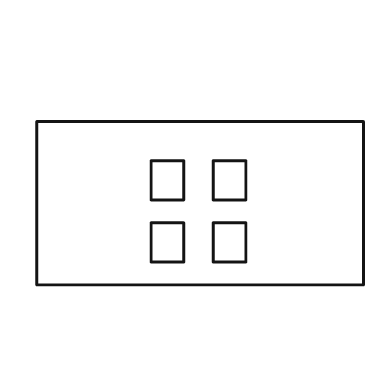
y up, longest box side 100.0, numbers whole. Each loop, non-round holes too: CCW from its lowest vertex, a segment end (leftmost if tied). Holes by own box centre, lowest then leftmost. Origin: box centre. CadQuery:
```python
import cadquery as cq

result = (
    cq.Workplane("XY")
    .moveTo(-50.0, -25.0)
    .lineTo(50.0, -25.0)
    .lineTo(50.0, 25.0)
    .lineTo(-50.0, 25.0)
    .close()
    .moveTo(-15.0, -18.0)
    .lineTo(-5.0, -18.0)
    .lineTo(-5.0, -6.0)
    .lineTo(-15.0, -6.0)
    .close()
    .moveTo(4.0, -18.0)
    .lineTo(14.0, -18.0)
    .lineTo(14.0, -6.0)
    .lineTo(4.0, -6.0)
    .close()
    .moveTo(-15.0, 1.0)
    .lineTo(-5.0, 1.0)
    .lineTo(-5.0, 13.0)
    .lineTo(-15.0, 13.0)
    .close()
    .moveTo(4.0, 1.0)
    .lineTo(14.0, 1.0)
    .lineTo(14.0, 13.0)
    .lineTo(4.0, 13.0)
    .close()
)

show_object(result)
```